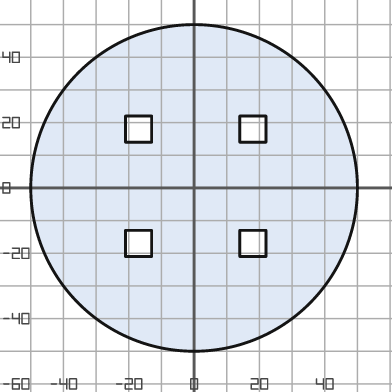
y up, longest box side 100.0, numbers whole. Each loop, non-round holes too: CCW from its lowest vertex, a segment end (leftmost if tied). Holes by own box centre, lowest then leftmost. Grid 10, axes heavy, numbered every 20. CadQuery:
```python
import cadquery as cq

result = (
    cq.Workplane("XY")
    .moveTo(0.0, 0.0)
    .circle(50.0)
    .moveTo(-21.0, -21.0)
    .lineTo(-13.0, -21.0)
    .lineTo(-13.0, -13.0)
    .lineTo(-21.0, -13.0)
    .close()
    .moveTo(14.0, -21.0)
    .lineTo(22.0, -21.0)
    .lineTo(22.0, -13.0)
    .lineTo(14.0, -13.0)
    .close()
    .moveTo(-21.0, 14.0)
    .lineTo(-13.0, 14.0)
    .lineTo(-13.0, 22.0)
    .lineTo(-21.0, 22.0)
    .close()
    .moveTo(14.0, 14.0)
    .lineTo(22.0, 14.0)
    .lineTo(22.0, 22.0)
    .lineTo(14.0, 22.0)
    .close()
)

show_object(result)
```